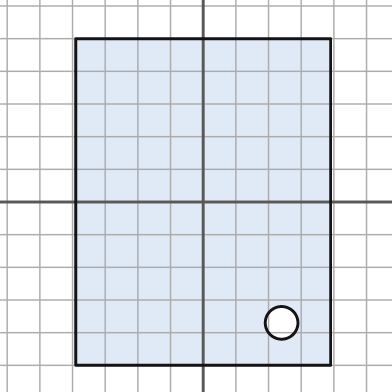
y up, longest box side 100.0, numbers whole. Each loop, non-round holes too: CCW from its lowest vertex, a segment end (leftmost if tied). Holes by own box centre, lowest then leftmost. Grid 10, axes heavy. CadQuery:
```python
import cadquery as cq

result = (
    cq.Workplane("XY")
    .moveTo(-39.0, -50.0)
    .lineTo(39.0, -50.0)
    .lineTo(39.0, 50.0)
    .lineTo(-39.0, 50.0)
    .close()
    .moveTo(24.0, -37.0)
    .circle(5.0)
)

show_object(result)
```